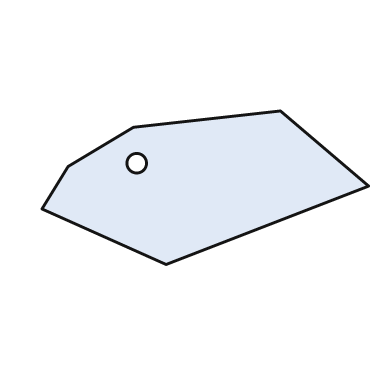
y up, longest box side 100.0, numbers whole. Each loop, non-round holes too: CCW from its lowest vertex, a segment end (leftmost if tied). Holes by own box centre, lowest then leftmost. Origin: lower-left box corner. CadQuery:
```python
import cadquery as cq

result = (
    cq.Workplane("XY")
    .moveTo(38.0, 0.0)
    .lineTo(100.0, 24.0)
    .lineTo(73.0, 47.0)
    .lineTo(28.0, 42.0)
    .lineTo(8.0, 30.0)
    .lineTo(0.0, 17.0)
    .close()
    .moveTo(29.0, 31.0)
    .circle(3.0)
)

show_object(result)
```